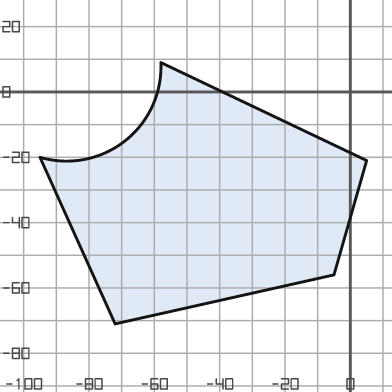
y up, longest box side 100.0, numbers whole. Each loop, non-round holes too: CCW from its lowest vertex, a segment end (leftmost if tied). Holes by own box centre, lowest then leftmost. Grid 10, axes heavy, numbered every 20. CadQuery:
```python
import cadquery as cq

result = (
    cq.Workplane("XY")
    .moveTo(-72.0, -71.0)
    .lineTo(-5.0, -56.0)
    .lineTo(5.0, -21.0)
    .lineTo(-58.0, 9.0)
    .threePointArc((-69.0, -15.0), (-95.0, -20.0))
    .close()
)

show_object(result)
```